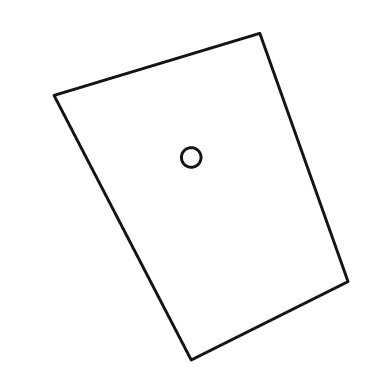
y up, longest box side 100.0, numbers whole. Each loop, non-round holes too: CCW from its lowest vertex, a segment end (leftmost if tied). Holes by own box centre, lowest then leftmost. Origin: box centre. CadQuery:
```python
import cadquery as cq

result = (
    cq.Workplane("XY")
    .moveTo(-3.0, -50.0)
    .lineTo(45.0, -26.0)
    .lineTo(18.0, 50.0)
    .lineTo(-45.0, 31.0)
    .close()
    .moveTo(-3.0, 12.0)
    .circle(3.0)
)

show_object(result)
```